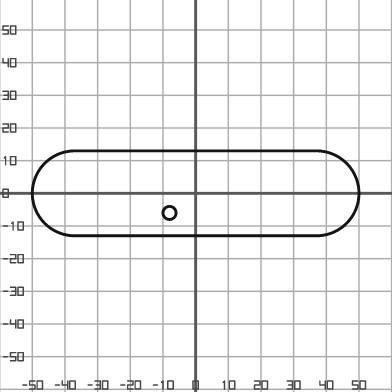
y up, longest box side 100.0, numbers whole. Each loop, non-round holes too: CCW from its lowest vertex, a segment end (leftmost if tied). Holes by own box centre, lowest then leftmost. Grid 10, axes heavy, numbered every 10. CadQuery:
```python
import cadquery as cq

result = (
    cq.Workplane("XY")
    .moveTo(-37.0, -13.0)
    .lineTo(37.0, -13.0)
    .threePointArc((50.0, 0.0), (37.0, 13.0))
    .lineTo(-37.0, 13.0)
    .threePointArc((-50.0, 0.0), (-37.0, -13.0))
    .close()
    .moveTo(-8.0, -6.0)
    .circle(2.0)
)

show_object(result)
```